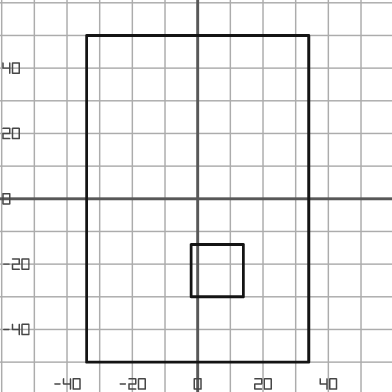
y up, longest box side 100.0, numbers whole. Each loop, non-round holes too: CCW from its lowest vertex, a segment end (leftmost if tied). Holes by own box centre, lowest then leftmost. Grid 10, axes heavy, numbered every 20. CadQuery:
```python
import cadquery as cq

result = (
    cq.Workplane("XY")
    .moveTo(-34.0, -50.0)
    .lineTo(34.0, -50.0)
    .lineTo(34.0, 50.0)
    .lineTo(-34.0, 50.0)
    .close()
    .moveTo(-2.0, -30.0)
    .lineTo(14.0, -30.0)
    .lineTo(14.0, -14.0)
    .lineTo(-2.0, -14.0)
    .close()
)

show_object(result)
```